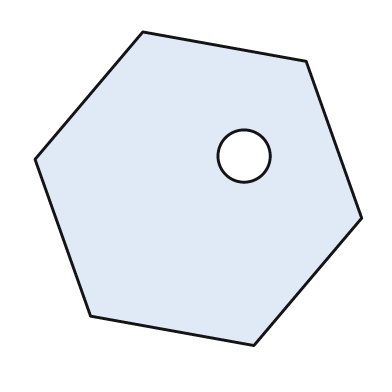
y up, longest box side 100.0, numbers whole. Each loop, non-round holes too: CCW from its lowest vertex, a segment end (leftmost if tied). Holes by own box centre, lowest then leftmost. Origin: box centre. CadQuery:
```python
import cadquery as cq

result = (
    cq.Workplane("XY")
    .moveTo(17.0, -48.0)
    .lineTo(50.0, -9.0)
    .lineTo(33.0, 39.0)
    .lineTo(-17.0, 48.0)
    .lineTo(-50.0, 9.0)
    .lineTo(-33.0, -39.0)
    .close()
    .moveTo(14.0, 10.0)
    .circle(8.0)
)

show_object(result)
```